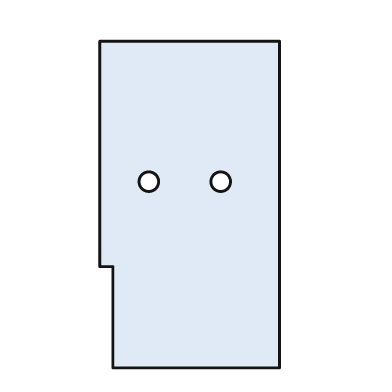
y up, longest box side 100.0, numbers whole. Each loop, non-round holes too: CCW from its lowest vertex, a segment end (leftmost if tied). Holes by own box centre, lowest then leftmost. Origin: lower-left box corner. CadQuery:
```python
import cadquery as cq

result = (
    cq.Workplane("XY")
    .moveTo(4.0, 0.0)
    .lineTo(55.0, 0.0)
    .lineTo(55.0, 100.0)
    .lineTo(0.0, 100.0)
    .lineTo(0.0, 31.0)
    .lineTo(4.0, 31.0)
    .close()
    .moveTo(15.0, 57.0)
    .circle(3.0)
    .moveTo(37.0, 57.0)
    .circle(3.0)
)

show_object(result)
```